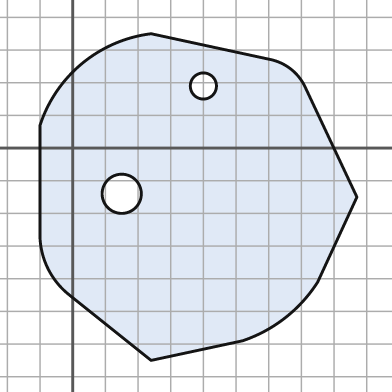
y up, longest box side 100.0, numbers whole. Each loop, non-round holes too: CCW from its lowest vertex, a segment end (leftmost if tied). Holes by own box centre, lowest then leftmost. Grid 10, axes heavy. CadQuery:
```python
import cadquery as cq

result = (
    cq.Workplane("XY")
    .moveTo(24.0, -65.0)
    .lineTo(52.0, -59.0)
    .threePointArc((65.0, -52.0), (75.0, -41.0))
    .lineTo(87.0, -15.0)
    .lineTo(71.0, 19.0)
    .threePointArc((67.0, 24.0), (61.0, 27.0))
    .lineTo(24.0, 35.0)
    .threePointArc((3.0, 26.0), (-10.0, 7.0))
    .lineTo(-10.0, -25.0)
    .threePointArc((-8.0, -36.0), (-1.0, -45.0))
    .close()
    .moveTo(15.0, -14.0)
    .circle(6.0)
    .moveTo(40.0, 19.0)
    .circle(4.0)
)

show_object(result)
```